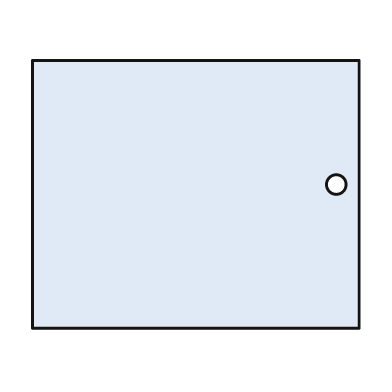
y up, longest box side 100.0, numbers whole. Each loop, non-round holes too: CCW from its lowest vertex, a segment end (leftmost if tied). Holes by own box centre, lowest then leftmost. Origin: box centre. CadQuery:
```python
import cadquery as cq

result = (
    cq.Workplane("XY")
    .moveTo(-50.0, -41.0)
    .lineTo(50.0, -41.0)
    .lineTo(50.0, 41.0)
    .lineTo(-50.0, 41.0)
    .close()
    .moveTo(43.0, 3.0)
    .circle(3.0)
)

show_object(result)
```